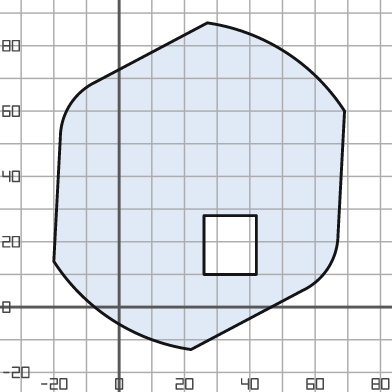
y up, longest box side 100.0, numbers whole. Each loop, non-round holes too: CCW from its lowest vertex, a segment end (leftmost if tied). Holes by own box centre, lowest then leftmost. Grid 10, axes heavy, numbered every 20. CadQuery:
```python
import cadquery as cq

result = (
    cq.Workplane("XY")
    .moveTo(22.0, -13.0)
    .lineTo(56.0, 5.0)
    .threePointArc((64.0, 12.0), (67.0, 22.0))
    .lineTo(69.0, 60.0)
    .threePointArc((51.0, 78.0), (27.0, 87.0))
    .lineTo(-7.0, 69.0)
    .threePointArc((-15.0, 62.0), (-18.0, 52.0))
    .lineTo(-20.0, 14.0)
    .threePointArc((-2.0, -4.0), (22.0, -13.0))
    .close()
    .moveTo(26.0, 10.0)
    .lineTo(42.0, 10.0)
    .lineTo(42.0, 28.0)
    .lineTo(26.0, 28.0)
    .close()
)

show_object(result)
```